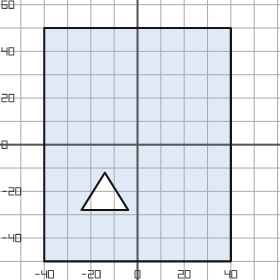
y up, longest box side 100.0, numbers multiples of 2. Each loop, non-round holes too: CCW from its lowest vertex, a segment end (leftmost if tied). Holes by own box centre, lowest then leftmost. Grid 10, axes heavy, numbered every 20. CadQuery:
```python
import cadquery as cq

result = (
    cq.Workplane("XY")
    .moveTo(-40.0, -50.0)
    .lineTo(40.0, -50.0)
    .lineTo(40.0, 50.0)
    .lineTo(-40.0, 50.0)
    .close()
    .moveTo(-24.0, -28.0)
    .lineTo(-4.0, -28.0)
    .lineTo(-14.0, -12.0)
    .close()
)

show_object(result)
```